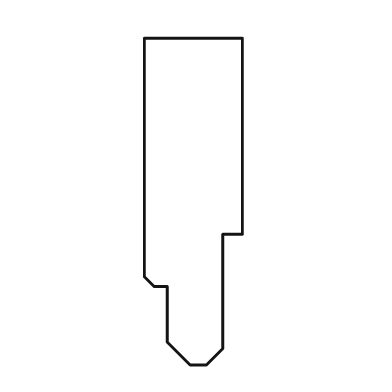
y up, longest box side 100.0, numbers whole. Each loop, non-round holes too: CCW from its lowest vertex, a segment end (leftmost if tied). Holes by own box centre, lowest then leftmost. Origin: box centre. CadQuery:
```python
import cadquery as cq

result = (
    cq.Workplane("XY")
    .moveTo(-1.0, -50.0)
    .lineTo(4.0, -50.0)
    .lineTo(9.0, -45.0)
    .lineTo(9.0, -10.0)
    .lineTo(15.0, -10.0)
    .lineTo(15.0, 50.0)
    .lineTo(-15.0, 50.0)
    .lineTo(-15.0, -23.0)
    .lineTo(-12.0, -26.0)
    .lineTo(-8.0, -26.0)
    .lineTo(-8.0, -43.0)
    .close()
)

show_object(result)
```